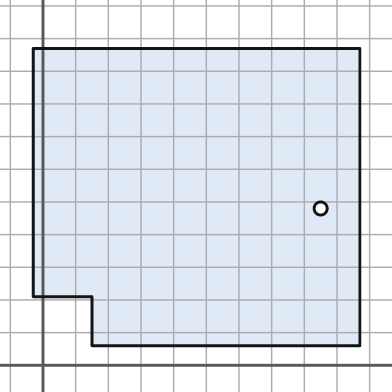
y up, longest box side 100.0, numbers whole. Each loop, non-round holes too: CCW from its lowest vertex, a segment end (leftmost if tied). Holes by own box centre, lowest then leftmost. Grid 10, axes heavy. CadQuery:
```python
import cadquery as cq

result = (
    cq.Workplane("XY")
    .moveTo(15.0, 6.0)
    .lineTo(97.0, 6.0)
    .lineTo(97.0, 97.0)
    .lineTo(-3.0, 97.0)
    .lineTo(-3.0, 21.0)
    .lineTo(15.0, 21.0)
    .close()
    .moveTo(85.0, 48.0)
    .circle(2.0)
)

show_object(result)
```